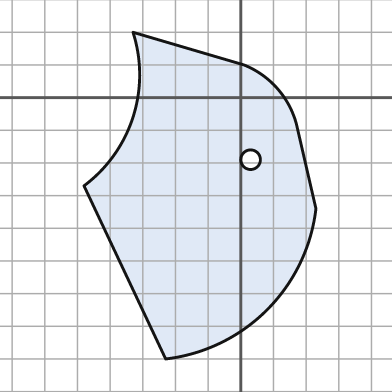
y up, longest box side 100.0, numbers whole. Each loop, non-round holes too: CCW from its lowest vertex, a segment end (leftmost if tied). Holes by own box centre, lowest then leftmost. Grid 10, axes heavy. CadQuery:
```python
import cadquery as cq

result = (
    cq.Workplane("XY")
    .moveTo(-23.0, -80.0)
    .threePointArc((8.0, -65.0), (23.0, -34.0))
    .lineTo(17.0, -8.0)
    .threePointArc((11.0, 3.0), (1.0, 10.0))
    .lineTo(-33.0, 20.0)
    .threePointArc((-33.0, -6.0), (-48.0, -27.0))
    .close()
    .moveTo(3.0, -19.0)
    .circle(3.0)
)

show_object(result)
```